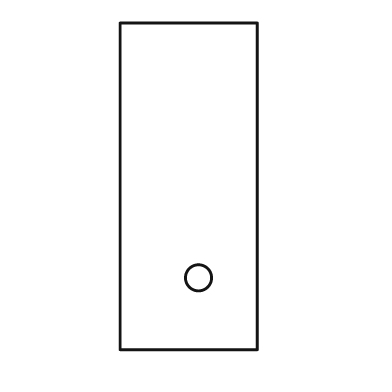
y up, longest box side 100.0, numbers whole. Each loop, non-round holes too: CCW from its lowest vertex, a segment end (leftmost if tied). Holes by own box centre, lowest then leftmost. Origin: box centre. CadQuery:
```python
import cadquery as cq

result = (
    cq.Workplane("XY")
    .moveTo(-21.0, -50.0)
    .lineTo(21.0, -50.0)
    .lineTo(21.0, 50.0)
    .lineTo(-21.0, 50.0)
    .close()
    .moveTo(3.0, -28.0)
    .circle(4.0)
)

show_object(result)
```